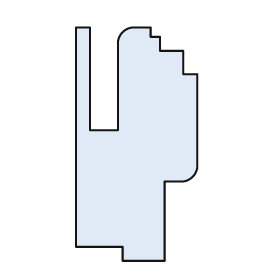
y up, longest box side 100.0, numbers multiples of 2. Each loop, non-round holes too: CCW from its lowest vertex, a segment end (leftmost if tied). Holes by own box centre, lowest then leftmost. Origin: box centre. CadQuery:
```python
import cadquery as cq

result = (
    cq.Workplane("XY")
    .moveTo(-6.0, -50.0)
    .lineTo(12.0, -50.0)
    .lineTo(12.0, -16.0)
    .lineTo(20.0, -16.0)
    .threePointArc((24.0, -14.0), (26.0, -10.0))
    .lineTo(26.0, 30.0)
    .lineTo(20.0, 30.0)
    .lineTo(20.0, 40.0)
    .lineTo(10.0, 40.0)
    .lineTo(10.0, 46.0)
    .lineTo(6.0, 46.0)
    .lineTo(6.0, 50.0)
    .lineTo(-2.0, 50.0)
    .threePointArc((-6.0, 48.0), (-8.0, 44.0))
    .lineTo(-8.0, 6.0)
    .lineTo(-20.0, 6.0)
    .lineTo(-20.0, 50.0)
    .lineTo(-26.0, 50.0)
    .lineTo(-26.0, -44.0)
    .lineTo(-6.0, -44.0)
    .close()
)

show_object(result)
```